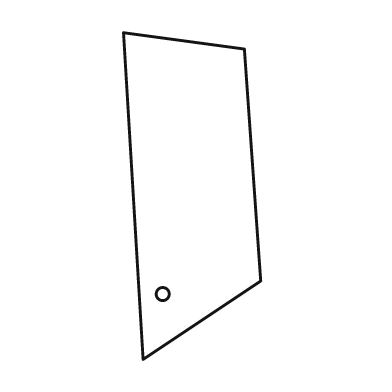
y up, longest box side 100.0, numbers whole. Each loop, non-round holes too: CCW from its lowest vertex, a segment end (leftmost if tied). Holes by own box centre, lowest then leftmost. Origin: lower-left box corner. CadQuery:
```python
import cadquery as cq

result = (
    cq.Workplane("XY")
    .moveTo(6.0, 0.0)
    .lineTo(42.0, 24.0)
    .lineTo(37.0, 95.0)
    .lineTo(0.0, 100.0)
    .close()
    .moveTo(12.0, 20.0)
    .circle(2.0)
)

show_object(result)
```